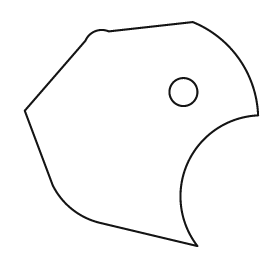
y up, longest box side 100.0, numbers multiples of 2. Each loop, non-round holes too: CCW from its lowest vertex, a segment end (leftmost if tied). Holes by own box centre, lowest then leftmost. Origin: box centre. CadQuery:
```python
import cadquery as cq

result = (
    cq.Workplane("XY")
    .moveTo(24.0, -48.0)
    .threePointArc((20.0, -12.0), (50.0, 8.0))
    .threePointArc((42.0, 32.0), (22.0, 48.0))
    .lineTo(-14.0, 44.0)
    .threePointArc((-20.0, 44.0), (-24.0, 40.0))
    .lineTo(-50.0, 10.0)
    .lineTo(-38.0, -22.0)
    .threePointArc((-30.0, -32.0), (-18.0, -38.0))
    .close()
    .moveTo(18.0, 18.0)
    .circle(6.0)
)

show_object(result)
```